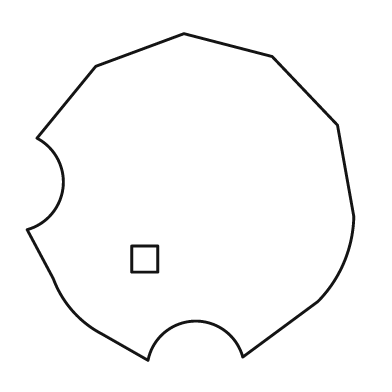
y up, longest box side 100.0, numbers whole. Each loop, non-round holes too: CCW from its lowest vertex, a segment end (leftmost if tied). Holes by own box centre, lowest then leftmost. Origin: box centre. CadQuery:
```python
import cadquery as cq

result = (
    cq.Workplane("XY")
    .moveTo(-13.0, -50.0)
    .threePointArc((1.0, -38.0), (16.0, -49.0))
    .lineTo(39.0, -32.0)
    .threePointArc((47.0, -20.0), (50.0, -6.0))
    .lineTo(45.0, 22.0)
    .lineTo(25.0, 43.0)
    .lineTo(-2.0, 50.0)
    .lineTo(-29.0, 40.0)
    .lineTo(-47.0, 18.0)
    .threePointArc((-39.0, 3.0), (-50.0, -10.0))
    .lineTo(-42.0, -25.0)
    .threePointArc((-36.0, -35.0), (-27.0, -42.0))
    .close()
    .moveTo(-18.0, -23.0)
    .lineTo(-10.0, -23.0)
    .lineTo(-10.0, -15.0)
    .lineTo(-18.0, -15.0)
    .close()
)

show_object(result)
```